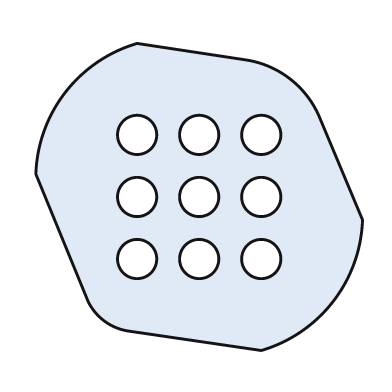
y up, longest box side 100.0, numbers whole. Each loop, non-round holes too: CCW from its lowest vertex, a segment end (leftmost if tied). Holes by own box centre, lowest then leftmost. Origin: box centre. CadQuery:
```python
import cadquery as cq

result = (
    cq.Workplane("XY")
    .moveTo(19.0, -47.0)
    .threePointArc((41.0, -32.0), (50.0, -7.0))
    .lineTo(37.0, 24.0)
    .threePointArc((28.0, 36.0), (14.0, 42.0))
    .lineTo(-19.0, 47.0)
    .threePointArc((-41.0, 32.0), (-50.0, 7.0))
    .lineTo(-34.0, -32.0)
    .threePointArc((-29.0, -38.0), (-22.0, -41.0))
    .close()
    .moveTo(-19.0, -19.0)
    .circle(6.0)
    .moveTo(0.0, -19.0)
    .circle(6.0)
    .moveTo(19.0, -19.0)
    .circle(6.0)
    .moveTo(-19.0, 0.0)
    .circle(6.0)
    .moveTo(0.0, 0.0)
    .circle(6.0)
    .moveTo(19.0, 0.0)
    .circle(6.0)
    .moveTo(-19.0, 19.0)
    .circle(6.0)
    .moveTo(0.0, 19.0)
    .circle(6.0)
    .moveTo(19.0, 19.0)
    .circle(6.0)
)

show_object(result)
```